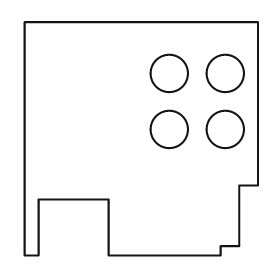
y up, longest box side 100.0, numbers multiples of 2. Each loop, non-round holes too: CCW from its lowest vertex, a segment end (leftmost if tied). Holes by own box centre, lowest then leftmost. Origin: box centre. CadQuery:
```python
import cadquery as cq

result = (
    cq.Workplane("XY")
    .moveTo(-50.0, -50.0)
    .lineTo(-44.0, -50.0)
    .lineTo(-44.0, -26.0)
    .lineTo(-14.0, -26.0)
    .lineTo(-14.0, -50.0)
    .lineTo(34.0, -50.0)
    .lineTo(34.0, -46.0)
    .lineTo(42.0, -46.0)
    .lineTo(42.0, -20.0)
    .lineTo(50.0, -20.0)
    .lineTo(50.0, 50.0)
    .lineTo(-50.0, 50.0)
    .close()
    .moveTo(12.0, 4.0)
    .circle(8.0)
    .moveTo(36.0, 4.0)
    .circle(8.0)
    .moveTo(12.0, 28.0)
    .circle(8.0)
    .moveTo(36.0, 28.0)
    .circle(8.0)
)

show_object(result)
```